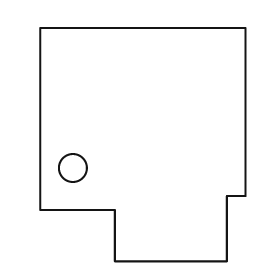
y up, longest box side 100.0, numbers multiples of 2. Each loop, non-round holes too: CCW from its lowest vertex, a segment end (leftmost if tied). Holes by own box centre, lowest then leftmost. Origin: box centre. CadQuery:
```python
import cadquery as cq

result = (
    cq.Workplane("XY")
    .moveTo(-12.0, -50.0)
    .lineTo(36.0, -50.0)
    .lineTo(36.0, -22.0)
    .lineTo(44.0, -22.0)
    .lineTo(44.0, 50.0)
    .lineTo(-44.0, 50.0)
    .lineTo(-44.0, -28.0)
    .lineTo(-12.0, -28.0)
    .close()
    .moveTo(-30.0, -10.0)
    .circle(6.0)
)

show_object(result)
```